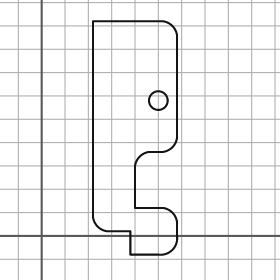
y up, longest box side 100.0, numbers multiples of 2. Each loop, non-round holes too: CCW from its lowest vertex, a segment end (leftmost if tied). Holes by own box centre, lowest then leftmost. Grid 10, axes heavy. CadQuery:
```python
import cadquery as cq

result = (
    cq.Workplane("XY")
    .moveTo(38.0, -8.0)
    .lineTo(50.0, -8.0)
    .threePointArc((56.0, -6.0), (58.0, 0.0))
    .lineTo(58.0, 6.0)
    .threePointArc((56.0, 10.0), (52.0, 12.0))
    .lineTo(40.0, 12.0)
    .lineTo(40.0, 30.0)
    .threePointArc((42.0, 34.0), (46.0, 36.0))
    .lineTo(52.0, 36.0)
    .threePointArc((56.0, 38.0), (58.0, 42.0))
    .lineTo(58.0, 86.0)
    .threePointArc((56.0, 90.0), (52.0, 92.0))
    .lineTo(22.0, 92.0)
    .lineTo(22.0, 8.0)
    .threePointArc((24.0, 4.0), (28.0, 2.0))
    .lineTo(38.0, 2.0)
    .close()
    .moveTo(50.0, 58.0)
    .circle(4.0)
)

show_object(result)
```